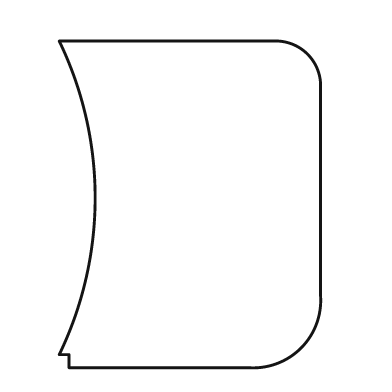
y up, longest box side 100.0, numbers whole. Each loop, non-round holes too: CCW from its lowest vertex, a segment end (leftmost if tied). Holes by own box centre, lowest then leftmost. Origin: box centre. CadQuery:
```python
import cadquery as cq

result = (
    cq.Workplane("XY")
    .moveTo(-37.0, -50.0)
    .lineTo(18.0, -50.0)
    .threePointArc((34.0, -44.0), (40.0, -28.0))
    .lineTo(40.0, 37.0)
    .threePointArc((36.0, 46.0), (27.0, 50.0))
    .lineTo(-40.0, 50.0)
    .threePointArc((-29.0, 2.0), (-40.0, -46.0))
    .lineTo(-37.0, -46.0)
    .close()
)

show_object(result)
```